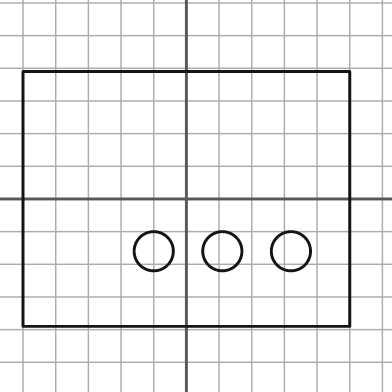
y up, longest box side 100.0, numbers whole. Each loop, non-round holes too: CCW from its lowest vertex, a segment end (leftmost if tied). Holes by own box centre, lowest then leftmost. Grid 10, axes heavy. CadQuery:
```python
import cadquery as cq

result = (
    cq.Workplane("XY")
    .moveTo(-50.0, -39.0)
    .lineTo(50.0, -39.0)
    .lineTo(50.0, 39.0)
    .lineTo(-50.0, 39.0)
    .close()
    .moveTo(-10.0, -16.0)
    .circle(6.0)
    .moveTo(11.0, -16.0)
    .circle(6.0)
    .moveTo(32.0, -16.0)
    .circle(6.0)
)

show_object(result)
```